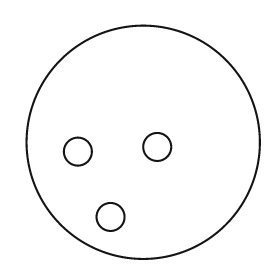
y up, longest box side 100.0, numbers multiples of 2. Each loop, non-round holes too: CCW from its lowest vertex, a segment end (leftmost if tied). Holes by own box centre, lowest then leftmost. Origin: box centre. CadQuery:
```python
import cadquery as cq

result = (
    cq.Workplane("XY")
    .moveTo(0.0, 0.0)
    .circle(50.0)
    .moveTo(-14.0, -32.0)
    .circle(6.0)
    .moveTo(-28.0, -4.0)
    .circle(6.0)
    .moveTo(6.0, -2.0)
    .circle(6.0)
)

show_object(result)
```